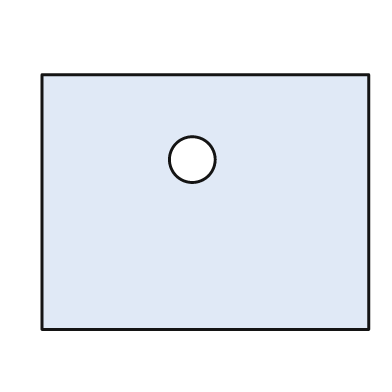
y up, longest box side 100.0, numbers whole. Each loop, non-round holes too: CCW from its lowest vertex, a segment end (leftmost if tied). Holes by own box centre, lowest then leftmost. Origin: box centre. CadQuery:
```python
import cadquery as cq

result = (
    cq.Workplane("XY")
    .moveTo(-50.0, -39.0)
    .lineTo(50.0, -39.0)
    .lineTo(50.0, 39.0)
    .lineTo(-50.0, 39.0)
    .close()
    .moveTo(-4.0, 13.0)
    .circle(7.0)
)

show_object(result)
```